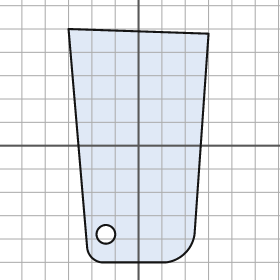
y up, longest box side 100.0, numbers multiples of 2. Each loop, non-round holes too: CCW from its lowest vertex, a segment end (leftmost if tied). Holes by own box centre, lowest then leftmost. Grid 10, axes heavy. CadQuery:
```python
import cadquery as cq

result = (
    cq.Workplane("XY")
    .moveTo(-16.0, -50.0)
    .lineTo(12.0, -50.0)
    .threePointArc((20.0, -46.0), (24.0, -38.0))
    .lineTo(30.0, 48.0)
    .lineTo(-30.0, 50.0)
    .lineTo(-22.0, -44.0)
    .threePointArc((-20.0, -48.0), (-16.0, -50.0))
    .close()
    .moveTo(-14.0, -38.0)
    .circle(4.0)
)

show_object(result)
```